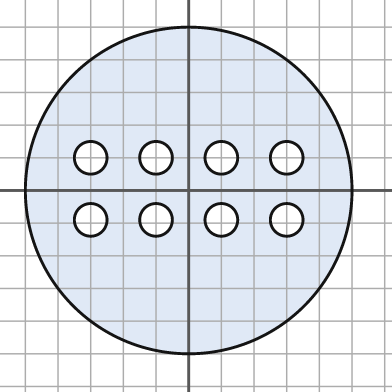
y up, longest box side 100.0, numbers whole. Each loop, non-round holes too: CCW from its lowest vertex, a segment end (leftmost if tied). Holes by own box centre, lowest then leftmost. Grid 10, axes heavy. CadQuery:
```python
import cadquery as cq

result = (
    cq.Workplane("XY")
    .moveTo(0.0, 0.0)
    .circle(50.0)
    .moveTo(-30.0, -9.0)
    .circle(5.0)
    .moveTo(-10.0, -9.0)
    .circle(5.0)
    .moveTo(10.0, -9.0)
    .circle(5.0)
    .moveTo(30.0, -9.0)
    .circle(5.0)
    .moveTo(-30.0, 10.0)
    .circle(5.0)
    .moveTo(-10.0, 10.0)
    .circle(5.0)
    .moveTo(10.0, 10.0)
    .circle(5.0)
    .moveTo(30.0, 10.0)
    .circle(5.0)
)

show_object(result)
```